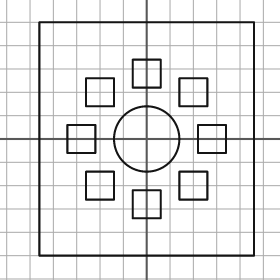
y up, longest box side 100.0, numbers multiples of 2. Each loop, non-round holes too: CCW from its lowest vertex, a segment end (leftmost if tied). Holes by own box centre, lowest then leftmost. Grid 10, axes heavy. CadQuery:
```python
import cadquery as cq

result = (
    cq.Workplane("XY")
    .moveTo(-46.0, -50.0)
    .lineTo(46.0, -50.0)
    .lineTo(46.0, 50.0)
    .lineTo(-46.0, 50.0)
    .close()
    .moveTo(-6.0, -34.0)
    .lineTo(6.0, -34.0)
    .lineTo(6.0, -22.0)
    .lineTo(-6.0, -22.0)
    .close()
    .moveTo(-26.0, -26.0)
    .lineTo(-14.0, -26.0)
    .lineTo(-14.0, -14.0)
    .lineTo(-26.0, -14.0)
    .close()
    .moveTo(14.0, -26.0)
    .lineTo(26.0, -26.0)
    .lineTo(26.0, -14.0)
    .lineTo(14.0, -14.0)
    .close()
    .moveTo(-34.0, -6.0)
    .lineTo(-22.0, -6.0)
    .lineTo(-22.0, 6.0)
    .lineTo(-34.0, 6.0)
    .close()
    .moveTo(0.0, 0.0)
    .circle(14.0)
    .moveTo(22.0, -6.0)
    .lineTo(34.0, -6.0)
    .lineTo(34.0, 6.0)
    .lineTo(22.0, 6.0)
    .close()
    .moveTo(-26.0, 14.0)
    .lineTo(-14.0, 14.0)
    .lineTo(-14.0, 26.0)
    .lineTo(-26.0, 26.0)
    .close()
    .moveTo(14.0, 14.0)
    .lineTo(26.0, 14.0)
    .lineTo(26.0, 26.0)
    .lineTo(14.0, 26.0)
    .close()
    .moveTo(-6.0, 22.0)
    .lineTo(6.0, 22.0)
    .lineTo(6.0, 34.0)
    .lineTo(-6.0, 34.0)
    .close()
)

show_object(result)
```